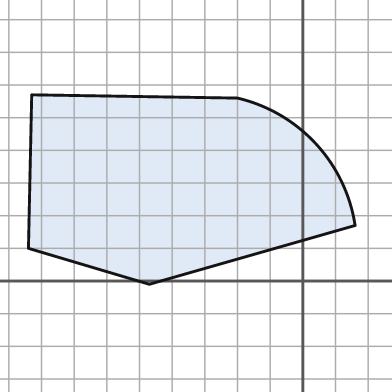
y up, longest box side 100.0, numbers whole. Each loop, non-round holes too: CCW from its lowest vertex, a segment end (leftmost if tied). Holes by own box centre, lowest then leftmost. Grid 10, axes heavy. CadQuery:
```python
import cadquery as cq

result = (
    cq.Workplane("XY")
    .moveTo(-47.0, -1.0)
    .lineTo(16.0, 17.0)
    .threePointArc((4.0, 42.0), (-20.0, 56.0))
    .lineTo(-83.0, 57.0)
    .lineTo(-84.0, 10.0)
    .close()
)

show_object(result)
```